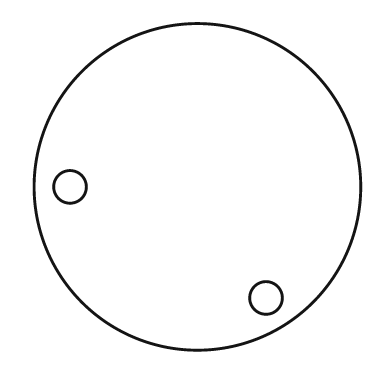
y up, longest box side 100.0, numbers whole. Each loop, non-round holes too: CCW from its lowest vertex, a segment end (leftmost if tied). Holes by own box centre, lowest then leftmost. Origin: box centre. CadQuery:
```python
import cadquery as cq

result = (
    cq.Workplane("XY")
    .moveTo(0.0, 0.0)
    .circle(50.0)
    .moveTo(21.0, -34.0)
    .circle(5.0)
    .moveTo(-39.0, 0.0)
    .circle(5.0)
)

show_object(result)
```